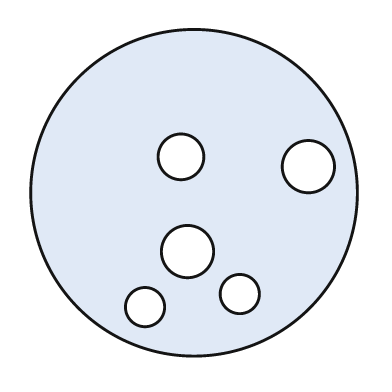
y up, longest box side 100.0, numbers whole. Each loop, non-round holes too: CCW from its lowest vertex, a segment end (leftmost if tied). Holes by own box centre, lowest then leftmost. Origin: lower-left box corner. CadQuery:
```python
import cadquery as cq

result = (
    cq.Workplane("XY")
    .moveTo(50.0, 50.0)
    .circle(50.0)
    .moveTo(35.0, 15.0)
    .circle(6.0)
    .moveTo(64.0, 19.0)
    .circle(6.0)
    .moveTo(48.0, 32.0)
    .circle(8.0)
    .moveTo(85.0, 58.0)
    .circle(8.0)
    .moveTo(46.0, 61.0)
    .circle(7.0)
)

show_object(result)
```